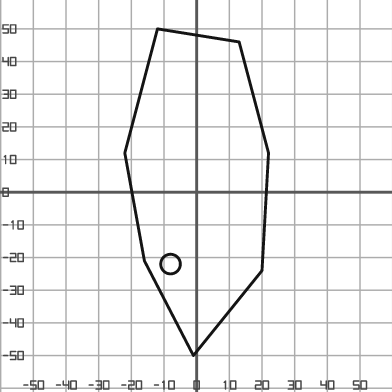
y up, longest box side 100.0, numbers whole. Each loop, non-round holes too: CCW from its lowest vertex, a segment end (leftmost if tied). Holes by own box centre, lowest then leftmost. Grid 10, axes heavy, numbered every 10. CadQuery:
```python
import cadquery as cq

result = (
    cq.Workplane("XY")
    .moveTo(-1.0, -50.0)
    .lineTo(20.0, -24.0)
    .lineTo(22.0, 12.0)
    .lineTo(13.0, 46.0)
    .lineTo(-12.0, 50.0)
    .lineTo(-22.0, 12.0)
    .lineTo(-16.0, -21.0)
    .close()
    .moveTo(-8.0, -22.0)
    .circle(3.0)
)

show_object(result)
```